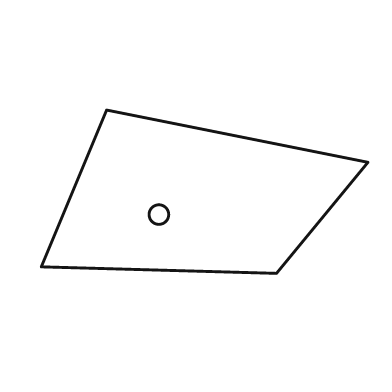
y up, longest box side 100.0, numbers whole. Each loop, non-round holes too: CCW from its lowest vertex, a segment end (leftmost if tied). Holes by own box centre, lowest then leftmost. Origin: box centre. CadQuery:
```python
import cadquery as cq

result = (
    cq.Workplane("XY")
    .moveTo(22.0, -25.0)
    .lineTo(50.0, 9.0)
    .lineTo(-30.0, 25.0)
    .lineTo(-50.0, -23.0)
    .close()
    .moveTo(-14.0, -7.0)
    .circle(3.0)
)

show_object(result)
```